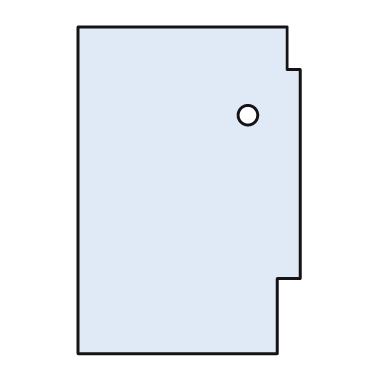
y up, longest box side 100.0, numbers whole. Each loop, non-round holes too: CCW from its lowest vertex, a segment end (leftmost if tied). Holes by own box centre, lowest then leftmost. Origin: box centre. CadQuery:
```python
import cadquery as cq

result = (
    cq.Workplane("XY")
    .moveTo(-34.0, -50.0)
    .lineTo(27.0, -50.0)
    .lineTo(27.0, -27.0)
    .lineTo(34.0, -27.0)
    .lineTo(34.0, 37.0)
    .lineTo(30.0, 37.0)
    .lineTo(30.0, 50.0)
    .lineTo(-34.0, 50.0)
    .close()
    .moveTo(18.0, 23.0)
    .circle(3.0)
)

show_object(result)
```